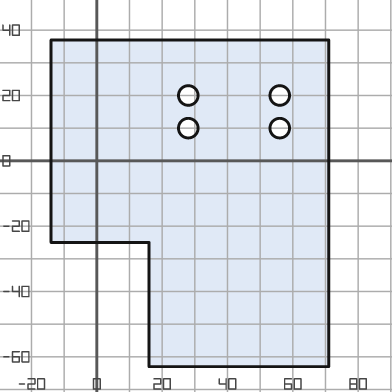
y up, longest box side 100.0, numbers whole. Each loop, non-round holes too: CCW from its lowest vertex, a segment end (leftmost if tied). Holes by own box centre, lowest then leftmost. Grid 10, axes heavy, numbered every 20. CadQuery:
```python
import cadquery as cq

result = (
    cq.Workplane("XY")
    .moveTo(16.0, -63.0)
    .lineTo(71.0, -63.0)
    .lineTo(71.0, 37.0)
    .lineTo(-14.0, 37.0)
    .lineTo(-14.0, -25.0)
    .lineTo(16.0, -25.0)
    .close()
    .moveTo(28.0, 10.0)
    .circle(3.0)
    .moveTo(56.0, 10.0)
    .circle(3.0)
    .moveTo(28.0, 20.0)
    .circle(3.0)
    .moveTo(56.0, 20.0)
    .circle(3.0)
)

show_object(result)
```